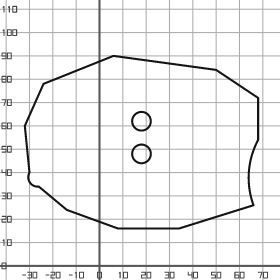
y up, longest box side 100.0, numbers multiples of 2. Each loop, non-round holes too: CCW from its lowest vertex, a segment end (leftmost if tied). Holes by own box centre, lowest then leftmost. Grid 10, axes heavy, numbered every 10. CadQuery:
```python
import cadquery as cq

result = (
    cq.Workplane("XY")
    .moveTo(8.0, 16.0)
    .lineTo(34.0, 16.0)
    .lineTo(66.0, 26.0)
    .threePointArc((64.0, 40.0), (68.0, 54.0))
    .lineTo(68.0, 72.0)
    .lineTo(50.0, 84.0)
    .lineTo(6.0, 90.0)
    .lineTo(-24.0, 78.0)
    .lineTo(-32.0, 60.0)
    .lineTo(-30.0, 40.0)
    .threePointArc((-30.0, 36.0), (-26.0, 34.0))
    .lineTo(-14.0, 24.0)
    .close()
    .moveTo(18.0, 48.0)
    .circle(4.0)
    .moveTo(18.0, 62.0)
    .circle(4.0)
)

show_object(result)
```